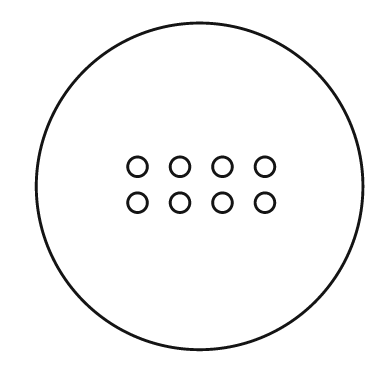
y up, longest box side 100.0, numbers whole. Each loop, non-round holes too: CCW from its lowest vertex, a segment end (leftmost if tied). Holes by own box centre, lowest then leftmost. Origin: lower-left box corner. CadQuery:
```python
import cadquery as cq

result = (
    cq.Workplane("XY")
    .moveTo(50.0, 50.0)
    .circle(50.0)
    .moveTo(31.0, 45.0)
    .circle(3.0)
    .moveTo(44.0, 45.0)
    .circle(3.0)
    .moveTo(57.0, 45.0)
    .circle(3.0)
    .moveTo(70.0, 45.0)
    .circle(3.0)
    .moveTo(31.0, 56.0)
    .circle(3.0)
    .moveTo(44.0, 56.0)
    .circle(3.0)
    .moveTo(57.0, 56.0)
    .circle(3.0)
    .moveTo(70.0, 56.0)
    .circle(3.0)
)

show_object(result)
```